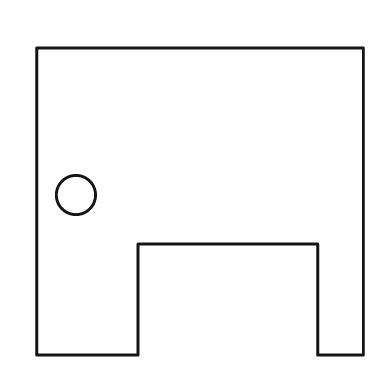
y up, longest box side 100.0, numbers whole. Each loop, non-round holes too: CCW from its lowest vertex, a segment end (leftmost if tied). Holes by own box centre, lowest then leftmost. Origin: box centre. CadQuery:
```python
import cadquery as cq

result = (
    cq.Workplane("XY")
    .moveTo(-50.0, -47.0)
    .lineTo(-19.0, -47.0)
    .lineTo(-19.0, -13.0)
    .lineTo(36.0, -13.0)
    .lineTo(36.0, -47.0)
    .lineTo(50.0, -47.0)
    .lineTo(50.0, 47.0)
    .lineTo(-50.0, 47.0)
    .close()
    .moveTo(-38.0, 2.0)
    .circle(6.0)
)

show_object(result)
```